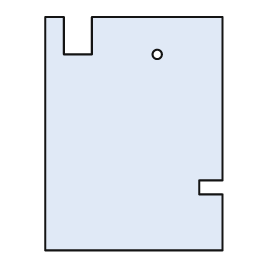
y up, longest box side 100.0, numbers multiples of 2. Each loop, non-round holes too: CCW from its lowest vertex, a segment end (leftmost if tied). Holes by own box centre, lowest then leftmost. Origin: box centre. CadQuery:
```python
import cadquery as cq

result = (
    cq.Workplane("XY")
    .moveTo(-38.0, -50.0)
    .lineTo(38.0, -50.0)
    .lineTo(38.0, -26.0)
    .lineTo(28.0, -26.0)
    .lineTo(28.0, -20.0)
    .lineTo(38.0, -20.0)
    .lineTo(38.0, 50.0)
    .lineTo(-18.0, 50.0)
    .lineTo(-18.0, 34.0)
    .lineTo(-30.0, 34.0)
    .lineTo(-30.0, 50.0)
    .lineTo(-38.0, 50.0)
    .close()
    .moveTo(10.0, 34.0)
    .circle(2.0)
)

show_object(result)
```